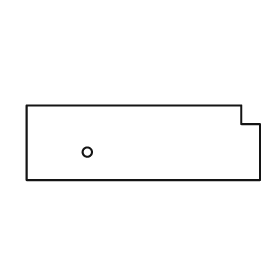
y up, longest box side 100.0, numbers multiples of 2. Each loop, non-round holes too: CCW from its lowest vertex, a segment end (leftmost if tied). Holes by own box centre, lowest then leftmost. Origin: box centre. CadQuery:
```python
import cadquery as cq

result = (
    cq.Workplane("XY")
    .moveTo(-50.0, -16.0)
    .lineTo(50.0, -16.0)
    .lineTo(50.0, 8.0)
    .lineTo(42.0, 8.0)
    .lineTo(42.0, 16.0)
    .lineTo(-50.0, 16.0)
    .close()
    .moveTo(-24.0, -4.0)
    .circle(2.0)
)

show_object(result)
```